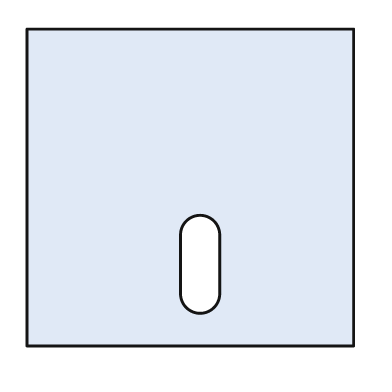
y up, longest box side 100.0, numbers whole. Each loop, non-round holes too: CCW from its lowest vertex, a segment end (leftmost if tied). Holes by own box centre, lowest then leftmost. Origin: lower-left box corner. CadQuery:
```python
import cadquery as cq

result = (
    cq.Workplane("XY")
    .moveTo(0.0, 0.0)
    .lineTo(100.0, 0.0)
    .lineTo(100.0, 97.0)
    .lineTo(0.0, 97.0)
    .close()
    .moveTo(47.0, 16.0)
    .threePointArc((53.0, 10.0), (59.0, 16.0))
    .lineTo(59.0, 34.0)
    .threePointArc((53.0, 40.0), (47.0, 34.0))
    .close()
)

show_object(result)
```